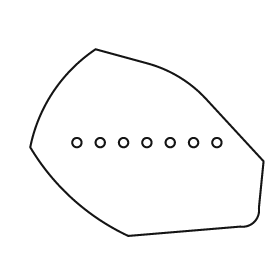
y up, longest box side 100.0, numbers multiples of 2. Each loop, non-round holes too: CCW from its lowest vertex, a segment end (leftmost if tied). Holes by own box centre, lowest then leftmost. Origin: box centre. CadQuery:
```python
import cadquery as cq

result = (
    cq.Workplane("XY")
    .moveTo(-8.0, -40.0)
    .lineTo(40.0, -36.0)
    .threePointArc((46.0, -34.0), (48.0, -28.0))
    .lineTo(50.0, -8.0)
    .lineTo(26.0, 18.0)
    .threePointArc((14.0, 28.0), (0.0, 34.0))
    .lineTo(-22.0, 40.0)
    .threePointArc((-40.0, 22.0), (-50.0, -2.0))
    .threePointArc((-32.0, -24.0), (-8.0, -40.0))
    .close()
    .moveTo(-30.0, 0.0)
    .circle(2.0)
    .moveTo(-20.0, 0.0)
    .circle(2.0)
    .moveTo(-10.0, 0.0)
    .circle(2.0)
    .moveTo(0.0, 0.0)
    .circle(2.0)
    .moveTo(10.0, 0.0)
    .circle(2.0)
    .moveTo(20.0, 0.0)
    .circle(2.0)
    .moveTo(30.0, 0.0)
    .circle(2.0)
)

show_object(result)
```